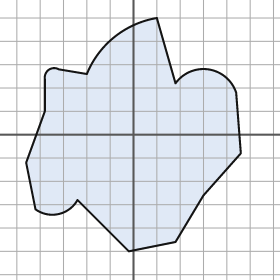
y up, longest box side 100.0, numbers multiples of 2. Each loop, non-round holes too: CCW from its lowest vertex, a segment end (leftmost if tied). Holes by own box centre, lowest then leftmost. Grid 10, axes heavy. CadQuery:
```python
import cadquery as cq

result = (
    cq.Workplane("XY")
    .moveTo(-2.0, -50.0)
    .lineTo(18.0, -46.0)
    .lineTo(30.0, -26.0)
    .lineTo(46.0, -8.0)
    .lineTo(44.0, 18.0)
    .threePointArc((32.0, 28.0), (18.0, 22.0))
    .lineTo(10.0, 50.0)
    .threePointArc((-8.0, 42.0), (-20.0, 26.0))
    .lineTo(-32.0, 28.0)
    .threePointArc((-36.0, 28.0), (-38.0, 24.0))
    .lineTo(-38.0, 10.0)
    .lineTo(-46.0, -12.0)
    .lineTo(-42.0, -32.0)
    .threePointArc((-32.0, -34.0), (-24.0, -28.0))
    .close()
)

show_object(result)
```